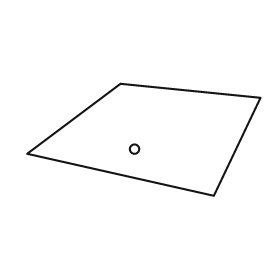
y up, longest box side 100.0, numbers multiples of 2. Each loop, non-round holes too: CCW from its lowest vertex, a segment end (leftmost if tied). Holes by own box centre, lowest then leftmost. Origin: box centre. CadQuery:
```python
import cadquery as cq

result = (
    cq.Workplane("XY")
    .moveTo(30.0, -24.0)
    .lineTo(50.0, 18.0)
    .lineTo(-10.0, 24.0)
    .lineTo(-50.0, -6.0)
    .close()
    .moveTo(-4.0, -4.0)
    .circle(2.0)
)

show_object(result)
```